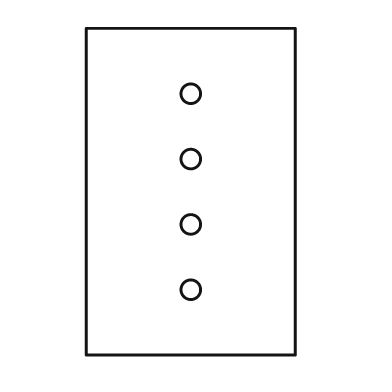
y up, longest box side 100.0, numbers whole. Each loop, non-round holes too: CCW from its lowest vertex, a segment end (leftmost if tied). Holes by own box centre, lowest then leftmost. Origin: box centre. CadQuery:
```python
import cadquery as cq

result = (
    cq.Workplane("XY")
    .moveTo(-32.0, -50.0)
    .lineTo(32.0, -50.0)
    .lineTo(32.0, 50.0)
    .lineTo(-32.0, 50.0)
    .close()
    .moveTo(0.0, -30.0)
    .circle(3.0)
    .moveTo(0.0, -10.0)
    .circle(3.0)
    .moveTo(0.0, 10.0)
    .circle(3.0)
    .moveTo(0.0, 30.0)
    .circle(3.0)
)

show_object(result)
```